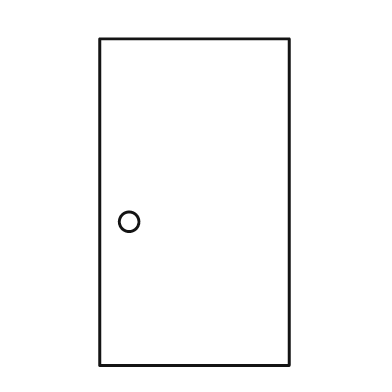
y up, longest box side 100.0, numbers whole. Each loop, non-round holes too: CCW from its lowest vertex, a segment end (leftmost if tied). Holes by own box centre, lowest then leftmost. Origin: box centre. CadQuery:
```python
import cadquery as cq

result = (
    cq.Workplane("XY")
    .moveTo(-29.0, -50.0)
    .lineTo(29.0, -50.0)
    .lineTo(29.0, 50.0)
    .lineTo(-29.0, 50.0)
    .close()
    .moveTo(-20.0, -6.0)
    .circle(3.0)
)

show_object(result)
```